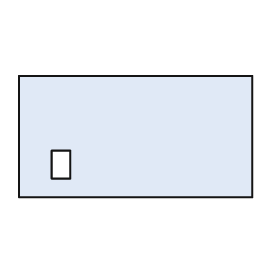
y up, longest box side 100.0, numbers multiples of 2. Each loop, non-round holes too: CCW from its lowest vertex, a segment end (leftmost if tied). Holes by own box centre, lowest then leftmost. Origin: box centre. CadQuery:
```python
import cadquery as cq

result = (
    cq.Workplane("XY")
    .moveTo(-50.0, -26.0)
    .lineTo(50.0, -26.0)
    .lineTo(50.0, 26.0)
    .lineTo(-50.0, 26.0)
    .close()
    .moveTo(-36.0, -18.0)
    .lineTo(-28.0, -18.0)
    .lineTo(-28.0, -6.0)
    .lineTo(-36.0, -6.0)
    .close()
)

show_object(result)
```